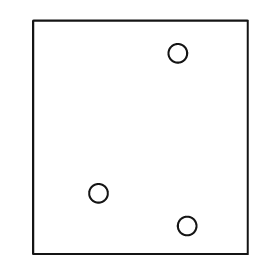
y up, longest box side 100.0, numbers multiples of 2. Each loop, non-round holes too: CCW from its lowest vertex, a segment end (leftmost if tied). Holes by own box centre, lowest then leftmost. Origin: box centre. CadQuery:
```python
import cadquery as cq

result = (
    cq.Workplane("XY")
    .moveTo(-46.0, -50.0)
    .lineTo(46.0, -50.0)
    .lineTo(46.0, 50.0)
    .lineTo(-46.0, 50.0)
    .close()
    .moveTo(20.0, -38.0)
    .circle(4.0)
    .moveTo(-18.0, -24.0)
    .circle(4.0)
    .moveTo(16.0, 36.0)
    .circle(4.0)
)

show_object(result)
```